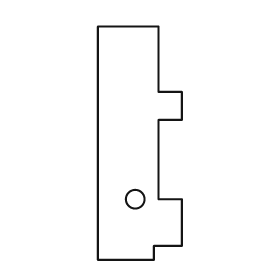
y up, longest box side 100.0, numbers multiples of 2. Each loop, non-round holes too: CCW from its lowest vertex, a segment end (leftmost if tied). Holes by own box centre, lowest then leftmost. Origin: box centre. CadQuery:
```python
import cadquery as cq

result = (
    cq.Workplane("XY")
    .moveTo(-18.0, -50.0)
    .lineTo(6.0, -50.0)
    .lineTo(6.0, -44.0)
    .lineTo(18.0, -44.0)
    .lineTo(18.0, -24.0)
    .lineTo(8.0, -24.0)
    .lineTo(8.0, 10.0)
    .lineTo(18.0, 10.0)
    .lineTo(18.0, 22.0)
    .lineTo(8.0, 22.0)
    .lineTo(8.0, 50.0)
    .lineTo(-18.0, 50.0)
    .close()
    .moveTo(-2.0, -24.0)
    .circle(4.0)
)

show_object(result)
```